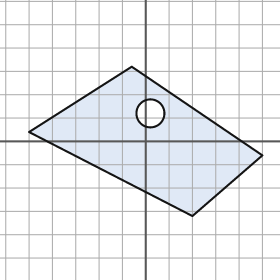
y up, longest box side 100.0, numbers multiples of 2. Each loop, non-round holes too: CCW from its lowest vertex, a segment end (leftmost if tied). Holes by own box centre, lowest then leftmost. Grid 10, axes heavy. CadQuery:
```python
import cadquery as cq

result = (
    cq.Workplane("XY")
    .moveTo(20.0, -32.0)
    .lineTo(50.0, -6.0)
    .lineTo(-6.0, 32.0)
    .lineTo(-50.0, 4.0)
    .close()
    .moveTo(2.0, 12.0)
    .circle(6.0)
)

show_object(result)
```